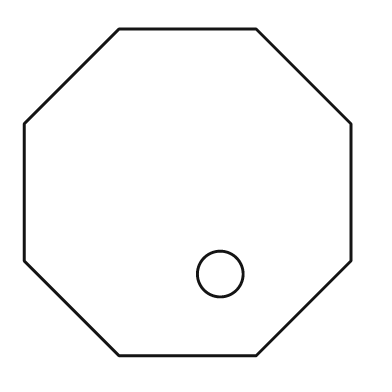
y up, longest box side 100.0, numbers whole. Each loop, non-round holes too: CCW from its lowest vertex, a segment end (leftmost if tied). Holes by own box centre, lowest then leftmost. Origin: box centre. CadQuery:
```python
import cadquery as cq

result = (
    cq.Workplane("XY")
    .moveTo(-21.0, -50.0)
    .lineTo(21.0, -50.0)
    .lineTo(50.0, -21.0)
    .lineTo(50.0, 21.0)
    .lineTo(21.0, 50.0)
    .lineTo(-21.0, 50.0)
    .lineTo(-50.0, 21.0)
    .lineTo(-50.0, -21.0)
    .close()
    .moveTo(10.0, -25.0)
    .circle(7.0)
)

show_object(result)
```